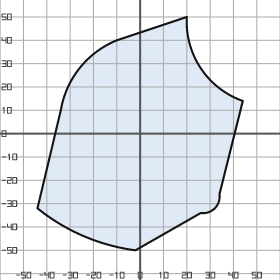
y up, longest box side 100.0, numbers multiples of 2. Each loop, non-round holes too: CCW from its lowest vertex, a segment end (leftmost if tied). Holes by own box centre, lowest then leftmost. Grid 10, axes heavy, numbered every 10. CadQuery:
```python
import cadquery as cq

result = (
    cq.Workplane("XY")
    .moveTo(-2.0, -50.0)
    .lineTo(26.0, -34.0)
    .threePointArc((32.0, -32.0), (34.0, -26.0))
    .lineTo(44.0, 14.0)
    .threePointArc((26.0, 28.0), (20.0, 50.0))
    .lineTo(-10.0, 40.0)
    .threePointArc((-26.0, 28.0), (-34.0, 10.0))
    .lineTo(-44.0, -32.0)
    .threePointArc((-24.0, -44.0), (-2.0, -50.0))
    .close()
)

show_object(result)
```